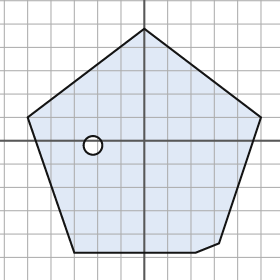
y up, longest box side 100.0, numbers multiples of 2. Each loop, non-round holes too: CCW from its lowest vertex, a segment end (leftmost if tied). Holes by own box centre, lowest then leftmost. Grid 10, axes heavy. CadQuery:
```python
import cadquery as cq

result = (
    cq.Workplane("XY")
    .moveTo(-30.0, -48.0)
    .lineTo(22.0, -48.0)
    .lineTo(32.0, -44.0)
    .lineTo(50.0, 10.0)
    .lineTo(0.0, 48.0)
    .lineTo(-50.0, 10.0)
    .close()
    .moveTo(-22.0, -2.0)
    .circle(4.0)
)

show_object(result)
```